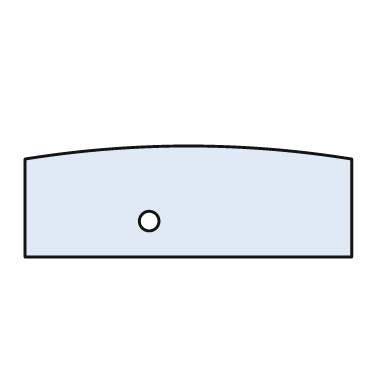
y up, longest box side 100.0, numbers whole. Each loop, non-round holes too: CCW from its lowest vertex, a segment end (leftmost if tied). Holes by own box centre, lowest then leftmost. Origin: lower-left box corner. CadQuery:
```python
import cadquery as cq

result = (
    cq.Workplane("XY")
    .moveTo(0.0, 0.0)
    .lineTo(100.0, 0.0)
    .lineTo(100.0, 30.0)
    .threePointArc((50.0, 34.0), (0.0, 30.0))
    .close()
    .moveTo(38.0, 11.0)
    .circle(3.0)
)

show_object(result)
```